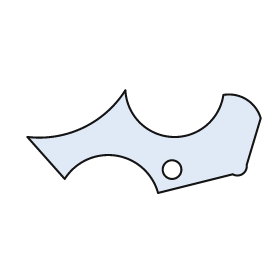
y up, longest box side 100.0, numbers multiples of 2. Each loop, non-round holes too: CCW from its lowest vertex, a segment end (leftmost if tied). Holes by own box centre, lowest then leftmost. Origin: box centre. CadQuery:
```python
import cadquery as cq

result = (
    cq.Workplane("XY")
    .moveTo(6.0, -22.0)
    .lineTo(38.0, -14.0)
    .threePointArc((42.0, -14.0), (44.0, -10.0))
    .lineTo(50.0, 10.0)
    .threePointArc((44.0, 18.0), (34.0, 20.0))
    .threePointArc((12.0, 2.0), (-8.0, 22.0))
    .threePointArc((-26.0, 6.0), (-50.0, 2.0))
    .lineTo(-34.0, -16.0)
    .threePointArc((-12.0, -6.0), (6.0, -22.0))
    .close()
    .moveTo(12.0, -12.0)
    .circle(4.0)
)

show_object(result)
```